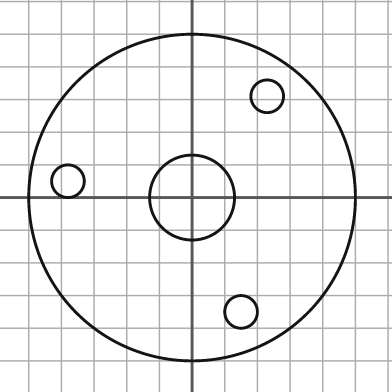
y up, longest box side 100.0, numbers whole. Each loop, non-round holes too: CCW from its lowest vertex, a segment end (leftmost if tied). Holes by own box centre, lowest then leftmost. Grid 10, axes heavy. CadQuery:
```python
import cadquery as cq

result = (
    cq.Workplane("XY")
    .moveTo(0.0, 0.0)
    .circle(50.0)
    .moveTo(15.0, -35.0)
    .circle(5.0)
    .moveTo(0.0, 0.0)
    .circle(13.0)
    .moveTo(-38.0, 5.0)
    .circle(5.0)
    .moveTo(23.0, 31.0)
    .circle(5.0)
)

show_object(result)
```